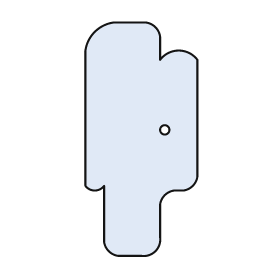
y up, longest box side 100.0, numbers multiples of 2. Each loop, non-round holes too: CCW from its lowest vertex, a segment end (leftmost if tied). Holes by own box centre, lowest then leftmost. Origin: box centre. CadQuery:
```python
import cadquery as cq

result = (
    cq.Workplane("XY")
    .moveTo(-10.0, -50.0)
    .lineTo(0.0, -50.0)
    .threePointArc((6.0, -48.0), (8.0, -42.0))
    .lineTo(8.0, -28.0)
    .threePointArc((10.0, -24.0), (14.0, -22.0))
    .lineTo(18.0, -22.0)
    .threePointArc((22.0, -20.0), (24.0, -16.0))
    .lineTo(24.0, 34.0)
    .threePointArc((16.0, 38.0), (8.0, 34.0))
    .lineTo(8.0, 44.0)
    .threePointArc((6.0, 48.0), (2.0, 50.0))
    .lineTo(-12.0, 50.0)
    .threePointArc((-20.0, 46.0), (-24.0, 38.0))
    .lineTo(-24.0, -20.0)
    .threePointArc((-20.0, -22.0), (-16.0, -20.0))
    .lineTo(-16.0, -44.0)
    .threePointArc((-14.0, -48.0), (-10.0, -50.0))
    .close()
    .moveTo(10.0, 4.0)
    .circle(2.0)
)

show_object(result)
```